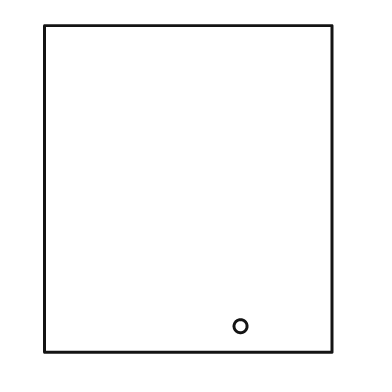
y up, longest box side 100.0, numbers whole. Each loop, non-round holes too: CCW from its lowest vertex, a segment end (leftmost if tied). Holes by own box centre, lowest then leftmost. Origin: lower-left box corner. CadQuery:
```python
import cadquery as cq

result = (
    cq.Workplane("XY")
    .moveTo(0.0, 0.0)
    .lineTo(88.0, 0.0)
    .lineTo(88.0, 100.0)
    .lineTo(0.0, 100.0)
    .close()
    .moveTo(60.0, 8.0)
    .circle(2.0)
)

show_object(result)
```